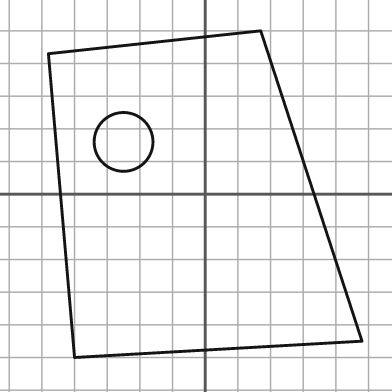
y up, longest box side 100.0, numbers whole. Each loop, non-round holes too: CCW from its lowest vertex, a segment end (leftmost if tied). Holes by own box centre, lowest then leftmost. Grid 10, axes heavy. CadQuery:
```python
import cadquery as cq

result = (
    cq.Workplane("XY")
    .moveTo(-40.0, -50.0)
    .lineTo(48.0, -45.0)
    .lineTo(17.0, 50.0)
    .lineTo(-48.0, 43.0)
    .close()
    .moveTo(-25.0, 16.0)
    .circle(9.0)
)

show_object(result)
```